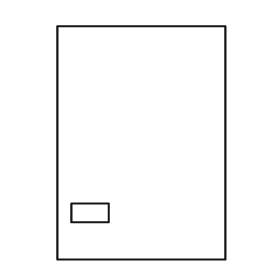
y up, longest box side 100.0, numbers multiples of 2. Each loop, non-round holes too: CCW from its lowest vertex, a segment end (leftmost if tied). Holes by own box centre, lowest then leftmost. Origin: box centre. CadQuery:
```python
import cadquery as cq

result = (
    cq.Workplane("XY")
    .moveTo(-36.0, -50.0)
    .lineTo(36.0, -50.0)
    .lineTo(36.0, 50.0)
    .lineTo(-36.0, 50.0)
    .close()
    .moveTo(-30.0, -34.0)
    .lineTo(-14.0, -34.0)
    .lineTo(-14.0, -26.0)
    .lineTo(-30.0, -26.0)
    .close()
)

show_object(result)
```